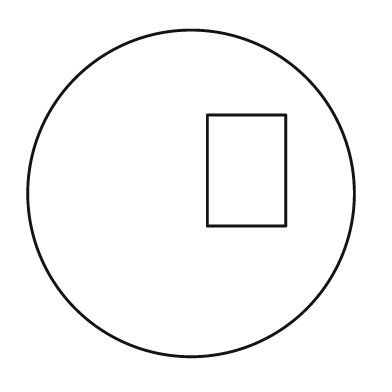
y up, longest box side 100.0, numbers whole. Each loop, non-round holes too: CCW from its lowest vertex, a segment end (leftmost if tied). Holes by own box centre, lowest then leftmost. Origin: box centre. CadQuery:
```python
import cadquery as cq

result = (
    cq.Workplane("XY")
    .moveTo(0.0, 0.0)
    .circle(50.0)
    .moveTo(5.0, -10.0)
    .lineTo(29.0, -10.0)
    .lineTo(29.0, 24.0)
    .lineTo(5.0, 24.0)
    .close()
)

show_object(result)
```